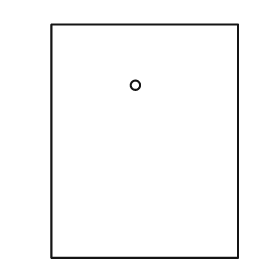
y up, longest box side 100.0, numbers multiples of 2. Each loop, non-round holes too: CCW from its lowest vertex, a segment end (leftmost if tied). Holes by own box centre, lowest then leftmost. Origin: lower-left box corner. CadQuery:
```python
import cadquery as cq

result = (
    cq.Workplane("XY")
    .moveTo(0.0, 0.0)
    .lineTo(80.0, 0.0)
    .lineTo(80.0, 100.0)
    .lineTo(0.0, 100.0)
    .close()
    .moveTo(36.0, 74.0)
    .circle(2.0)
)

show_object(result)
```